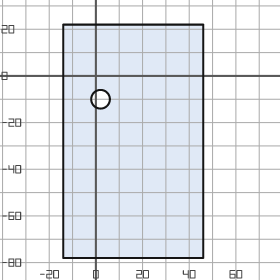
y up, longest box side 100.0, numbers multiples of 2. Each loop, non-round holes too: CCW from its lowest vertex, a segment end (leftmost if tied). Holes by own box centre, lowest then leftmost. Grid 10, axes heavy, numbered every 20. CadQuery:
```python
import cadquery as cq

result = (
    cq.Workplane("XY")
    .moveTo(-14.0, -78.0)
    .lineTo(46.0, -78.0)
    .lineTo(46.0, 22.0)
    .lineTo(-14.0, 22.0)
    .close()
    .moveTo(2.0, -10.0)
    .circle(4.0)
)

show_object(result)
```